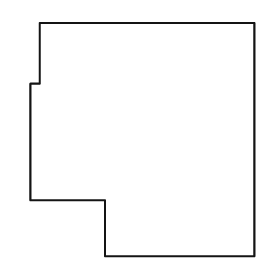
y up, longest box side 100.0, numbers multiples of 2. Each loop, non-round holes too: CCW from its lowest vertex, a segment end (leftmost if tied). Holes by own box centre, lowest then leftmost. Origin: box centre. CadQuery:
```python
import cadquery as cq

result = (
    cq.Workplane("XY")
    .moveTo(-16.0, -50.0)
    .lineTo(48.0, -50.0)
    .lineTo(48.0, 50.0)
    .lineTo(-44.0, 50.0)
    .lineTo(-44.0, 24.0)
    .lineTo(-48.0, 24.0)
    .lineTo(-48.0, -26.0)
    .lineTo(-16.0, -26.0)
    .close()
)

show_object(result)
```